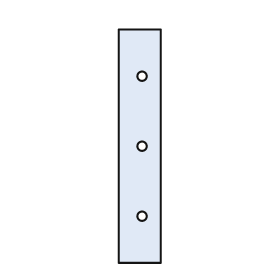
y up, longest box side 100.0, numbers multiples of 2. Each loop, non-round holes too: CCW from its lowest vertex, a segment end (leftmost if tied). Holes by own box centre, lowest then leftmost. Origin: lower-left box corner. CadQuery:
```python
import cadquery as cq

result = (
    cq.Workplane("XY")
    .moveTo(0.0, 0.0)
    .lineTo(18.0, 0.0)
    .lineTo(18.0, 100.0)
    .lineTo(0.0, 100.0)
    .close()
    .moveTo(10.0, 20.0)
    .circle(2.0)
    .moveTo(10.0, 50.0)
    .circle(2.0)
    .moveTo(10.0, 80.0)
    .circle(2.0)
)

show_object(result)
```